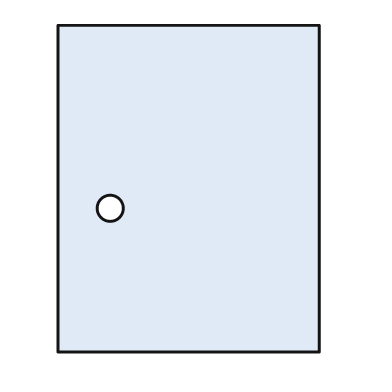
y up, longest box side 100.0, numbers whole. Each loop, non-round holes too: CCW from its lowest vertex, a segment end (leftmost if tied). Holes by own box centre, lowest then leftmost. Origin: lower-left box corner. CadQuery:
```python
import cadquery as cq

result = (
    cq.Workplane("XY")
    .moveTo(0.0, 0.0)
    .lineTo(80.0, 0.0)
    .lineTo(80.0, 100.0)
    .lineTo(0.0, 100.0)
    .close()
    .moveTo(16.0, 44.0)
    .circle(4.0)
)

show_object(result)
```